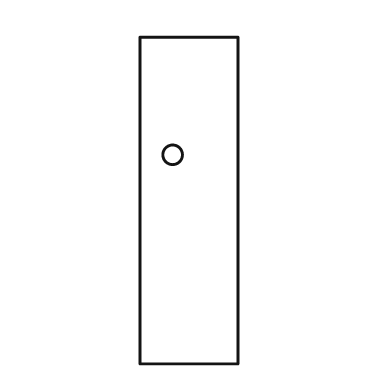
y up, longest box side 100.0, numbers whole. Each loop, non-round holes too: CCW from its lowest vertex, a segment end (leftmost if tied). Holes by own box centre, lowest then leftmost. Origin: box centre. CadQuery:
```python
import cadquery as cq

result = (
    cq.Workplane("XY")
    .moveTo(-15.0, -50.0)
    .lineTo(15.0, -50.0)
    .lineTo(15.0, 50.0)
    .lineTo(-15.0, 50.0)
    .close()
    .moveTo(-5.0, 14.0)
    .circle(3.0)
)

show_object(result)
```